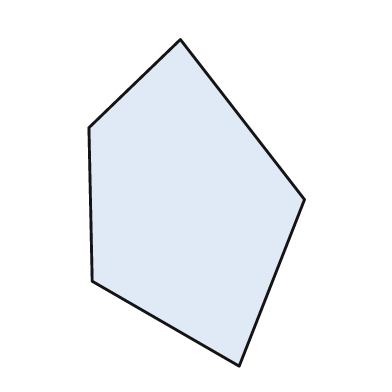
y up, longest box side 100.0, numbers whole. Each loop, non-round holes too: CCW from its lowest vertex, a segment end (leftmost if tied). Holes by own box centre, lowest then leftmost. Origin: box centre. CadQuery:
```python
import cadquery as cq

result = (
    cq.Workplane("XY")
    .moveTo(13.0, -50.0)
    .lineTo(33.0, 1.0)
    .lineTo(-5.0, 50.0)
    .lineTo(-33.0, 23.0)
    .lineTo(-32.0, -24.0)
    .close()
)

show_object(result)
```